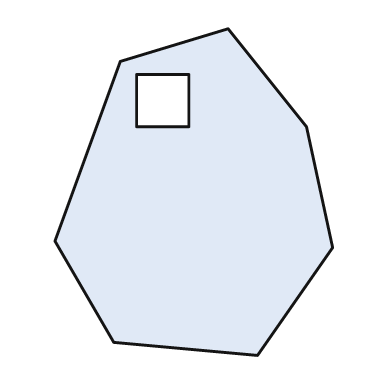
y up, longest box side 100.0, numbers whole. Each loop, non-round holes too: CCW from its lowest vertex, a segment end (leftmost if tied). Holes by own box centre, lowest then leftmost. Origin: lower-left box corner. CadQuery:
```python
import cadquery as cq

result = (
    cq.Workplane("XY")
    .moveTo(62.0, 0.0)
    .lineTo(85.0, 33.0)
    .lineTo(77.0, 70.0)
    .lineTo(53.0, 100.0)
    .lineTo(20.0, 90.0)
    .lineTo(0.0, 35.0)
    .lineTo(18.0, 4.0)
    .close()
    .moveTo(25.0, 70.0)
    .lineTo(41.0, 70.0)
    .lineTo(41.0, 86.0)
    .lineTo(25.0, 86.0)
    .close()
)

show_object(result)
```